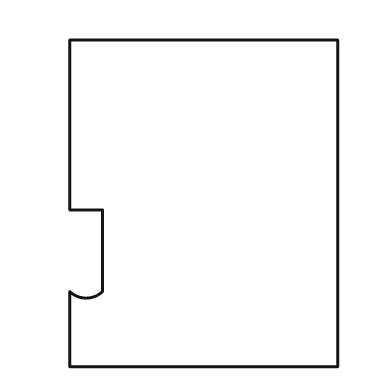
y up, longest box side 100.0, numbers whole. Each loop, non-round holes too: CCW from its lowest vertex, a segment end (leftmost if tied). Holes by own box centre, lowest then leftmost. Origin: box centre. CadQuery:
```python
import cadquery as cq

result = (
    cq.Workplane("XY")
    .moveTo(-41.0, -50.0)
    .lineTo(41.0, -50.0)
    .lineTo(41.0, 50.0)
    .lineTo(-41.0, 50.0)
    .lineTo(-41.0, -2.0)
    .lineTo(-31.0, -2.0)
    .lineTo(-31.0, -27.0)
    .threePointArc((-36.0, -29.0), (-41.0, -27.0))
    .close()
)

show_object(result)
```